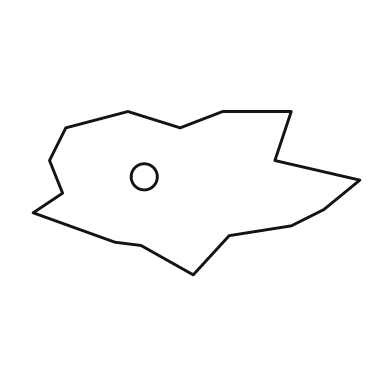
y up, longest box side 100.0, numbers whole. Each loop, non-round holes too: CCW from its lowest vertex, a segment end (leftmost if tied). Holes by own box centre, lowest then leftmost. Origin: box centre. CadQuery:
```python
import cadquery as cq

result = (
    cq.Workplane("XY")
    .moveTo(-1.0, -25.0)
    .lineTo(10.0, -13.0)
    .lineTo(29.0, -10.0)
    .lineTo(39.0, -5.0)
    .lineTo(50.0, 4.0)
    .lineTo(24.0, 10.0)
    .lineTo(29.0, 25.0)
    .lineTo(8.0, 25.0)
    .lineTo(-5.0, 20.0)
    .lineTo(-21.0, 25.0)
    .lineTo(-40.0, 20.0)
    .lineTo(-45.0, 10.0)
    .lineTo(-41.0, 0.0)
    .lineTo(-50.0, -6.0)
    .lineTo(-25.0, -15.0)
    .lineTo(-17.0, -16.0)
    .close()
    .moveTo(-16.0, 5.0)
    .circle(4.0)
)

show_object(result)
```